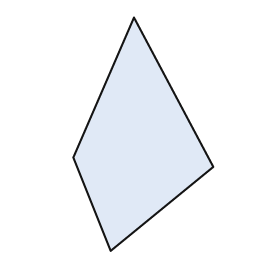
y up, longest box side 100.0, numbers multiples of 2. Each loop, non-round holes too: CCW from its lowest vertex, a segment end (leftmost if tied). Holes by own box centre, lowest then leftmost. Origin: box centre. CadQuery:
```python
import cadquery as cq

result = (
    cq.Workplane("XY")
    .moveTo(-14.0, -50.0)
    .lineTo(30.0, -14.0)
    .lineTo(-4.0, 50.0)
    .lineTo(-30.0, -10.0)
    .close()
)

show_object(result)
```